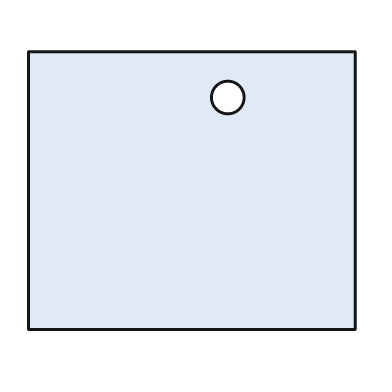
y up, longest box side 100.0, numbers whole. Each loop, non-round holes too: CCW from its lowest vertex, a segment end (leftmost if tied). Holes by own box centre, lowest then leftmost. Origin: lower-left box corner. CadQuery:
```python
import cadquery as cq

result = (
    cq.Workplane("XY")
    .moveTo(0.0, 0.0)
    .lineTo(100.0, 0.0)
    .lineTo(100.0, 85.0)
    .lineTo(0.0, 85.0)
    .close()
    .moveTo(61.0, 71.0)
    .circle(5.0)
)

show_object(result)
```